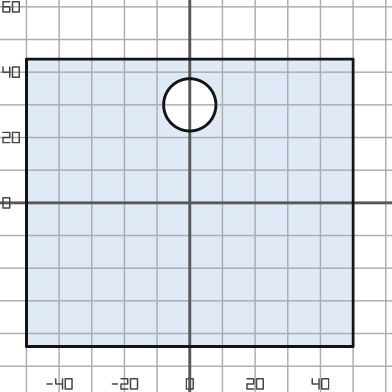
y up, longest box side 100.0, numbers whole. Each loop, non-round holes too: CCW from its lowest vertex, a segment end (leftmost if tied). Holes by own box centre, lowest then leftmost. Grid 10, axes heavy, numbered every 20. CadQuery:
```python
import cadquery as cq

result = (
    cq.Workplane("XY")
    .moveTo(-50.0, -44.0)
    .lineTo(50.0, -44.0)
    .lineTo(50.0, 44.0)
    .lineTo(-50.0, 44.0)
    .close()
    .moveTo(0.0, 30.0)
    .circle(8.0)
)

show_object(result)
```